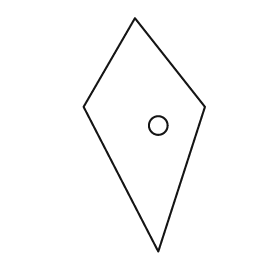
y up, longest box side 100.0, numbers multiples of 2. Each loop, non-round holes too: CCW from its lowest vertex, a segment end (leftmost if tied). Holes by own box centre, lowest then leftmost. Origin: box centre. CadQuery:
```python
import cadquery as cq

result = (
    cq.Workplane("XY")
    .moveTo(6.0, -50.0)
    .lineTo(26.0, 12.0)
    .lineTo(-4.0, 50.0)
    .lineTo(-26.0, 12.0)
    .close()
    .moveTo(6.0, 4.0)
    .circle(4.0)
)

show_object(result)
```